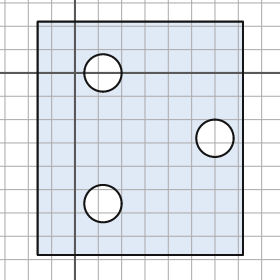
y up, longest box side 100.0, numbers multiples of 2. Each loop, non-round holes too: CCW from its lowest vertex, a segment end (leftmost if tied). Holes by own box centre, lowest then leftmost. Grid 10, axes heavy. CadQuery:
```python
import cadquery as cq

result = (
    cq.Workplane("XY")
    .moveTo(-16.0, -78.0)
    .lineTo(72.0, -78.0)
    .lineTo(72.0, 22.0)
    .lineTo(-16.0, 22.0)
    .close()
    .moveTo(12.0, -56.0)
    .circle(8.0)
    .moveTo(60.0, -28.0)
    .circle(8.0)
    .moveTo(12.0, 0.0)
    .circle(8.0)
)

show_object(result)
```